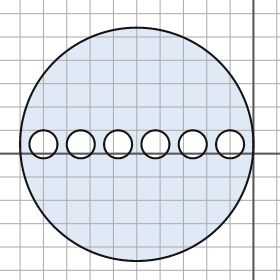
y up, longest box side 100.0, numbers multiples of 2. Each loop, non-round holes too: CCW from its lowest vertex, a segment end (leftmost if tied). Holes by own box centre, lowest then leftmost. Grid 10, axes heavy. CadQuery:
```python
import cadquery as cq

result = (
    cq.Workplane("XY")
    .moveTo(-50.0, 4.0)
    .circle(50.0)
    .moveTo(-90.0, 4.0)
    .circle(6.0)
    .moveTo(-74.0, 4.0)
    .circle(6.0)
    .moveTo(-58.0, 4.0)
    .circle(6.0)
    .moveTo(-42.0, 4.0)
    .circle(6.0)
    .moveTo(-26.0, 4.0)
    .circle(6.0)
    .moveTo(-10.0, 4.0)
    .circle(6.0)
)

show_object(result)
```